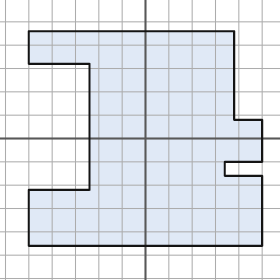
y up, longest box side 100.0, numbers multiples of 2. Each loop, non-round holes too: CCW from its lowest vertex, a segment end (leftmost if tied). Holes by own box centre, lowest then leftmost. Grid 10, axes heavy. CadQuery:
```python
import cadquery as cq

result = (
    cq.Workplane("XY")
    .moveTo(-50.0, -46.0)
    .lineTo(50.0, -46.0)
    .lineTo(50.0, -16.0)
    .lineTo(34.0, -16.0)
    .lineTo(34.0, -10.0)
    .lineTo(50.0, -10.0)
    .lineTo(50.0, 8.0)
    .lineTo(38.0, 8.0)
    .lineTo(38.0, 46.0)
    .lineTo(-50.0, 46.0)
    .lineTo(-50.0, 32.0)
    .lineTo(-24.0, 32.0)
    .lineTo(-24.0, -22.0)
    .lineTo(-50.0, -22.0)
    .close()
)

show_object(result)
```